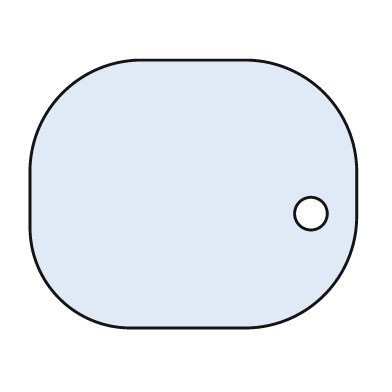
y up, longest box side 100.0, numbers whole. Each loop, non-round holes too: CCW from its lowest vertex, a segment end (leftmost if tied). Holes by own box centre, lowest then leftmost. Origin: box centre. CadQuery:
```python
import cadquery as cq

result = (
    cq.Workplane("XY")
    .moveTo(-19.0, -41.0)
    .lineTo(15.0, -41.0)
    .threePointArc((40.0, -31.0), (50.0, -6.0))
    .lineTo(50.0, 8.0)
    .threePointArc((40.0, 31.0), (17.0, 41.0))
    .lineTo(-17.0, 41.0)
    .threePointArc((-40.0, 31.0), (-50.0, 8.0))
    .lineTo(-50.0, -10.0)
    .threePointArc((-41.0, -32.0), (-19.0, -41.0))
    .close()
    .moveTo(36.0, -6.0)
    .circle(5.0)
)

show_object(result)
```